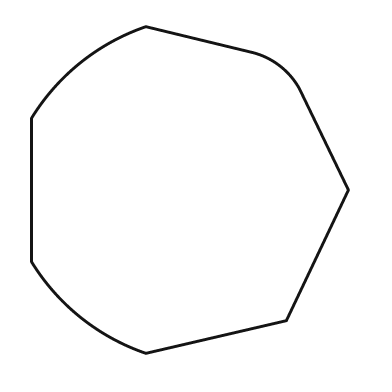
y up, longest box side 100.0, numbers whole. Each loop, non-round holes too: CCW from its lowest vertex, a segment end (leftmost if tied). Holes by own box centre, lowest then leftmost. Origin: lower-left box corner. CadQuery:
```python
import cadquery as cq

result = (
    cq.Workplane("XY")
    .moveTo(35.0, 0.0)
    .lineTo(78.0, 10.0)
    .lineTo(97.0, 50.0)
    .lineTo(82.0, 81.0)
    .threePointArc((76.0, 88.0), (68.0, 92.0))
    .lineTo(35.0, 100.0)
    .threePointArc((15.0, 89.0), (0.0, 72.0))
    .lineTo(0.0, 28.0)
    .threePointArc((15.0, 11.0), (35.0, 0.0))
    .close()
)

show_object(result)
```